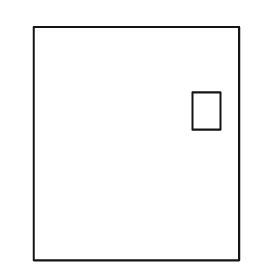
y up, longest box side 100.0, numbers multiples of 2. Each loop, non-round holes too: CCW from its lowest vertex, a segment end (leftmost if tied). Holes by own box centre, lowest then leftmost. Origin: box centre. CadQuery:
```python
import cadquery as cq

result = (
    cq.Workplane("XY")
    .moveTo(-44.0, -50.0)
    .lineTo(44.0, -50.0)
    .lineTo(44.0, 50.0)
    .lineTo(-44.0, 50.0)
    .close()
    .moveTo(24.0, 6.0)
    .lineTo(36.0, 6.0)
    .lineTo(36.0, 22.0)
    .lineTo(24.0, 22.0)
    .close()
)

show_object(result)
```